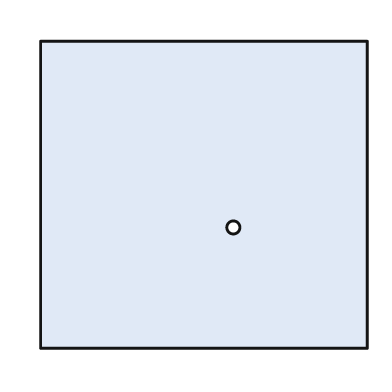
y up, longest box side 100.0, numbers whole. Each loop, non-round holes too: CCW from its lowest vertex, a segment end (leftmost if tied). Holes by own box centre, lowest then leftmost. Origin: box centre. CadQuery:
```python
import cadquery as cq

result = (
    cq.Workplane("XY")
    .moveTo(-50.0, -47.0)
    .lineTo(50.0, -47.0)
    .lineTo(50.0, 47.0)
    .lineTo(-50.0, 47.0)
    .close()
    .moveTo(9.0, -10.0)
    .circle(2.0)
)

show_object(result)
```